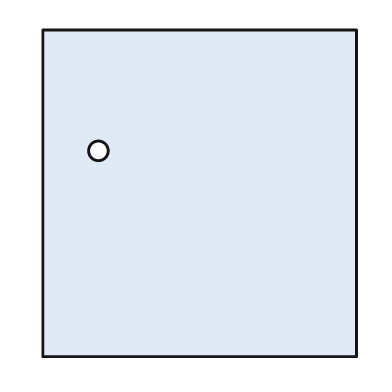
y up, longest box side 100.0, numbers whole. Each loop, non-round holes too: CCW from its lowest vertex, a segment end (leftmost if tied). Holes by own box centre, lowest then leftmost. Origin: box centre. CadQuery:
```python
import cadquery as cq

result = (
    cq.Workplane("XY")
    .moveTo(-48.0, -50.0)
    .lineTo(48.0, -50.0)
    .lineTo(48.0, 50.0)
    .lineTo(-48.0, 50.0)
    .close()
    .moveTo(-31.0, 13.0)
    .circle(3.0)
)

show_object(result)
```